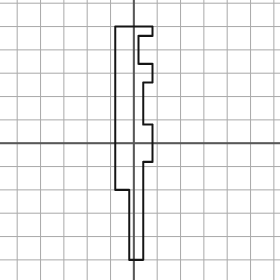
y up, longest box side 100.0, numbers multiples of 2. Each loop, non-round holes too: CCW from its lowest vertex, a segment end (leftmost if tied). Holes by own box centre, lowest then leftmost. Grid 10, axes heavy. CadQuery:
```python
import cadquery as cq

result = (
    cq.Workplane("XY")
    .moveTo(-2.0, -50.0)
    .lineTo(4.0, -50.0)
    .lineTo(4.0, -8.0)
    .lineTo(8.0, -8.0)
    .lineTo(8.0, 8.0)
    .lineTo(4.0, 8.0)
    .lineTo(4.0, 26.0)
    .lineTo(8.0, 26.0)
    .lineTo(8.0, 34.0)
    .lineTo(2.0, 34.0)
    .lineTo(2.0, 46.0)
    .lineTo(8.0, 46.0)
    .lineTo(8.0, 50.0)
    .lineTo(-8.0, 50.0)
    .lineTo(-8.0, -20.0)
    .lineTo(-2.0, -20.0)
    .close()
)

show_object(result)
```